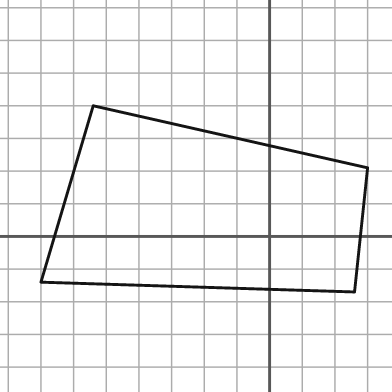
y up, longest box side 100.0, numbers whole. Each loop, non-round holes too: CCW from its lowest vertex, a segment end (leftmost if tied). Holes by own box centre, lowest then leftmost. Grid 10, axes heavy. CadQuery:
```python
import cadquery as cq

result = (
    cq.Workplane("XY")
    .moveTo(26.0, -17.0)
    .lineTo(30.0, 21.0)
    .lineTo(-54.0, 40.0)
    .lineTo(-70.0, -14.0)
    .close()
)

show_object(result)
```